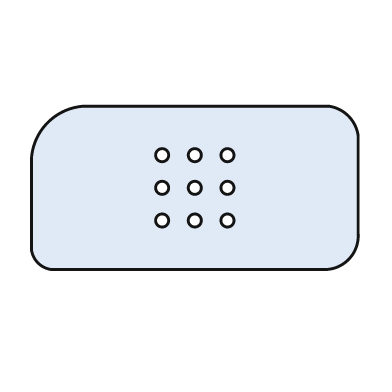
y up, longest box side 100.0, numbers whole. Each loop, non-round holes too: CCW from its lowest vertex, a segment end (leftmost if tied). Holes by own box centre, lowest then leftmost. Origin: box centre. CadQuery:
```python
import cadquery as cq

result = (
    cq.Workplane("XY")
    .moveTo(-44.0, -25.0)
    .lineTo(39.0, -25.0)
    .threePointArc((47.0, -22.0), (50.0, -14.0))
    .lineTo(50.0, 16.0)
    .threePointArc((47.0, 22.0), (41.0, 25.0))
    .lineTo(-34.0, 25.0)
    .threePointArc((-45.0, 20.0), (-50.0, 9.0))
    .lineTo(-50.0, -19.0)
    .threePointArc((-48.0, -23.0), (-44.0, -25.0))
    .close()
    .moveTo(-10.0, -10.0)
    .circle(2.0)
    .moveTo(0.0, -10.0)
    .circle(2.0)
    .moveTo(10.0, -10.0)
    .circle(2.0)
    .moveTo(-10.0, 0.0)
    .circle(2.0)
    .moveTo(0.0, 0.0)
    .circle(2.0)
    .moveTo(10.0, 0.0)
    .circle(2.0)
    .moveTo(-10.0, 10.0)
    .circle(2.0)
    .moveTo(0.0, 10.0)
    .circle(2.0)
    .moveTo(10.0, 10.0)
    .circle(2.0)
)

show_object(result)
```